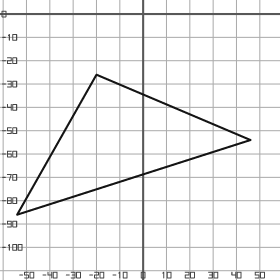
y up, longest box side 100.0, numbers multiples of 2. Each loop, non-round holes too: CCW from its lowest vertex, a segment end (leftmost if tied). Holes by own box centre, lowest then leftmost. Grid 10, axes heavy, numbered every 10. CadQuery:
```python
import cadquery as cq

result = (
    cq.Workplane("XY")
    .moveTo(-54.0, -86.0)
    .lineTo(46.0, -54.0)
    .lineTo(-20.0, -26.0)
    .close()
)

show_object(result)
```